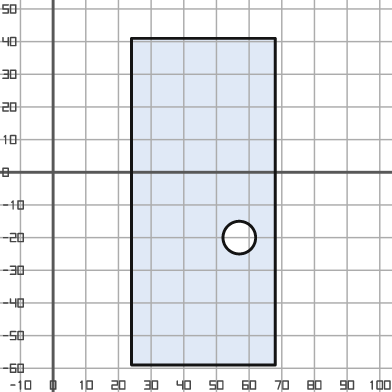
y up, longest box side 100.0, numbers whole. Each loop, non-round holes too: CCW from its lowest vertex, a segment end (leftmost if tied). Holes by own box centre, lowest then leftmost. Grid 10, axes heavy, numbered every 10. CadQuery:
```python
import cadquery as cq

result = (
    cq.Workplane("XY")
    .moveTo(24.0, -59.0)
    .lineTo(68.0, -59.0)
    .lineTo(68.0, 41.0)
    .lineTo(24.0, 41.0)
    .close()
    .moveTo(57.0, -20.0)
    .circle(5.0)
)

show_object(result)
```